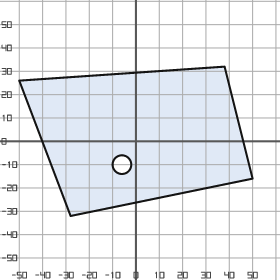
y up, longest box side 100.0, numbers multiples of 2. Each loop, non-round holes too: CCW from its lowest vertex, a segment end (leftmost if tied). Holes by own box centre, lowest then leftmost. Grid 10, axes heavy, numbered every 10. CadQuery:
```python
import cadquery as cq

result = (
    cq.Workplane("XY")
    .moveTo(-28.0, -32.0)
    .lineTo(50.0, -16.0)
    .lineTo(38.0, 32.0)
    .lineTo(-50.0, 26.0)
    .close()
    .moveTo(-6.0, -10.0)
    .circle(4.0)
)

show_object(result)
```